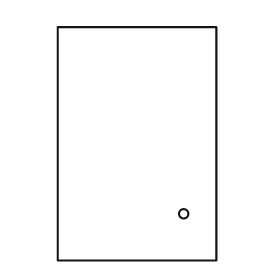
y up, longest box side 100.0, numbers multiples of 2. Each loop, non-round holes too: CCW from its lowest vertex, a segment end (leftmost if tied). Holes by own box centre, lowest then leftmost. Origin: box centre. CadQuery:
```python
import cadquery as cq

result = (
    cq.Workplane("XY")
    .moveTo(-34.0, -50.0)
    .lineTo(34.0, -50.0)
    .lineTo(34.0, 50.0)
    .lineTo(-34.0, 50.0)
    .close()
    .moveTo(20.0, -30.0)
    .circle(2.0)
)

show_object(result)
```